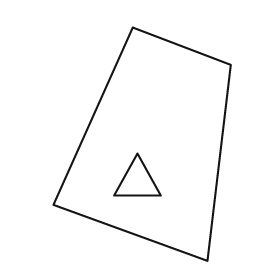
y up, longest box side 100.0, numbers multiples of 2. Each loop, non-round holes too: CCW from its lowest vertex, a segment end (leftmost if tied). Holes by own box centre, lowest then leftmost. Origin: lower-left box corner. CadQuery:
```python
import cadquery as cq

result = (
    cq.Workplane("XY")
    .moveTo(66.0, 0.0)
    .lineTo(76.0, 84.0)
    .lineTo(34.0, 100.0)
    .lineTo(0.0, 24.0)
    .close()
    .moveTo(26.0, 28.0)
    .lineTo(46.0, 28.0)
    .lineTo(36.0, 46.0)
    .close()
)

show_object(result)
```